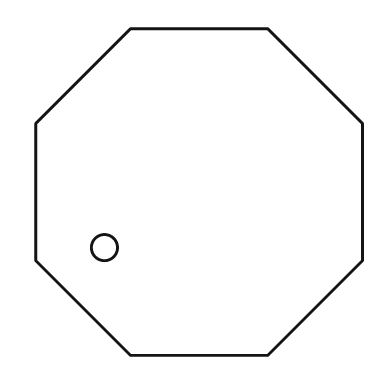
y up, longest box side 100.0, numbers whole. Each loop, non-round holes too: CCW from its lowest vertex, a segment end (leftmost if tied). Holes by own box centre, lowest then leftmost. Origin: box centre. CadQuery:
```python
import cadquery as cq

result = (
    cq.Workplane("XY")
    .moveTo(-21.0, -50.0)
    .lineTo(21.0, -50.0)
    .lineTo(50.0, -21.0)
    .lineTo(50.0, 21.0)
    .lineTo(21.0, 50.0)
    .lineTo(-21.0, 50.0)
    .lineTo(-50.0, 21.0)
    .lineTo(-50.0, -21.0)
    .close()
    .moveTo(-29.0, -17.0)
    .circle(4.0)
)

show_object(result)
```